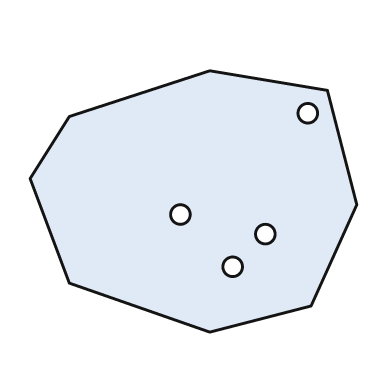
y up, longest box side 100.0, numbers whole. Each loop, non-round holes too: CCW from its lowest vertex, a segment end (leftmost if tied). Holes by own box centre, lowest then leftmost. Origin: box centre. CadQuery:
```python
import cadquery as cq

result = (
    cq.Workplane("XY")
    .moveTo(5.0, -40.0)
    .lineTo(36.0, -32.0)
    .lineTo(50.0, -1.0)
    .lineTo(41.0, 34.0)
    .lineTo(5.0, 40.0)
    .lineTo(-38.0, 26.0)
    .lineTo(-50.0, 7.0)
    .lineTo(-38.0, -25.0)
    .close()
    .moveTo(12.0, -20.0)
    .circle(3.0)
    .moveTo(22.0, -10.0)
    .circle(3.0)
    .moveTo(-4.0, -4.0)
    .circle(3.0)
    .moveTo(35.0, 27.0)
    .circle(3.0)
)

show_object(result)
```